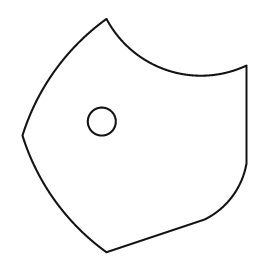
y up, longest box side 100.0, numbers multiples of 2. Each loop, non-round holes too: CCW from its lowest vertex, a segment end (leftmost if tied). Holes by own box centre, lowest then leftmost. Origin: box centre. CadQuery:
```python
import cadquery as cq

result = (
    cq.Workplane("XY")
    .moveTo(-12.0, -50.0)
    .lineTo(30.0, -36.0)
    .threePointArc((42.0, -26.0), (48.0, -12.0))
    .lineTo(48.0, 30.0)
    .threePointArc((14.0, 28.0), (-12.0, 50.0))
    .threePointArc((-34.0, 28.0), (-48.0, 0.0))
    .threePointArc((-34.0, -28.0), (-12.0, -50.0))
    .close()
    .moveTo(-14.0, 6.0)
    .circle(6.0)
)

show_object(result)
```